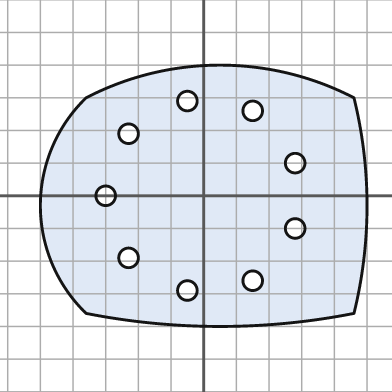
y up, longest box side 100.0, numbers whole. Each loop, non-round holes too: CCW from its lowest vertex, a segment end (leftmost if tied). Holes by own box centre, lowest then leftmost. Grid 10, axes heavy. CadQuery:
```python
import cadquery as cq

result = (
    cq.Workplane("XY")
    .moveTo(-36.0, -36.0)
    .threePointArc((5.0, -40.0), (46.0, -36.0))
    .threePointArc((50.0, -3.0), (46.0, 30.0))
    .threePointArc((5.0, 40.0), (-36.0, 30.0))
    .threePointArc((-50.0, -3.0), (-36.0, -36.0))
    .close()
    .moveTo(-5.0, -29.0)
    .circle(3.0)
    .moveTo(15.0, -26.0)
    .circle(3.0)
    .moveTo(-23.0, -19.0)
    .circle(3.0)
    .moveTo(28.0, -10.0)
    .circle(3.0)
    .moveTo(-30.0, 0.0)
    .circle(3.0)
    .moveTo(28.0, 10.0)
    .circle(3.0)
    .moveTo(-23.0, 19.0)
    .circle(3.0)
    .moveTo(15.0, 26.0)
    .circle(3.0)
    .moveTo(-5.0, 29.0)
    .circle(3.0)
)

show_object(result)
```